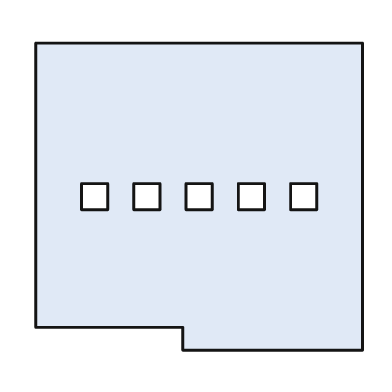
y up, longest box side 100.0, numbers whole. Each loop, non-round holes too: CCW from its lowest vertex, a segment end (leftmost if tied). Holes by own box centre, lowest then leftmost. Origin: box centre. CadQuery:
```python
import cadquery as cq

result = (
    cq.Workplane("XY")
    .moveTo(-5.0, -47.0)
    .lineTo(50.0, -47.0)
    .lineTo(50.0, 47.0)
    .lineTo(-50.0, 47.0)
    .lineTo(-50.0, -40.0)
    .lineTo(-5.0, -40.0)
    .close()
    .moveTo(-36.0, -4.0)
    .lineTo(-28.0, -4.0)
    .lineTo(-28.0, 4.0)
    .lineTo(-36.0, 4.0)
    .close()
    .moveTo(-20.0, -4.0)
    .lineTo(-12.0, -4.0)
    .lineTo(-12.0, 4.0)
    .lineTo(-20.0, 4.0)
    .close()
    .moveTo(-4.0, -4.0)
    .lineTo(4.0, -4.0)
    .lineTo(4.0, 4.0)
    .lineTo(-4.0, 4.0)
    .close()
    .moveTo(12.0, -4.0)
    .lineTo(20.0, -4.0)
    .lineTo(20.0, 4.0)
    .lineTo(12.0, 4.0)
    .close()
    .moveTo(28.0, -4.0)
    .lineTo(36.0, -4.0)
    .lineTo(36.0, 4.0)
    .lineTo(28.0, 4.0)
    .close()
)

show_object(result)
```